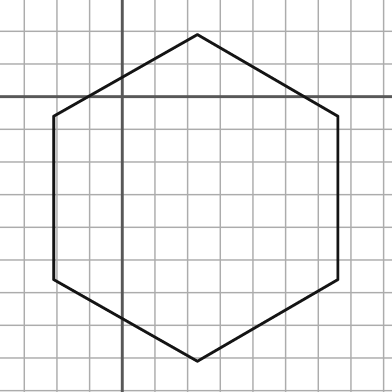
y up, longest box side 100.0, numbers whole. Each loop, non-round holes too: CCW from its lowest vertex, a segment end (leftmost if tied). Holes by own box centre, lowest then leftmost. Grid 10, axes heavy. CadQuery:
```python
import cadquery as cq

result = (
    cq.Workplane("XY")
    .moveTo(23.0, -81.0)
    .lineTo(66.0, -56.0)
    .lineTo(66.0, -6.0)
    .lineTo(23.0, 19.0)
    .lineTo(-21.0, -6.0)
    .lineTo(-21.0, -56.0)
    .close()
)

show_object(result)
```